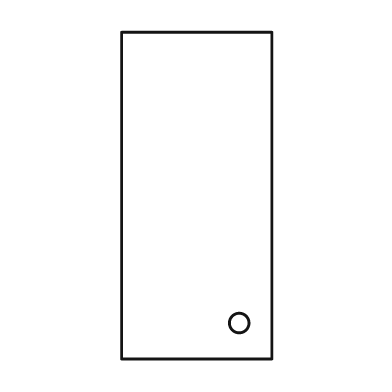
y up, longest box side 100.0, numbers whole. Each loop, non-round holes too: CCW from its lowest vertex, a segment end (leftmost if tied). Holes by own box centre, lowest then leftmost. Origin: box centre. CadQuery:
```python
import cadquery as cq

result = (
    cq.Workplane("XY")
    .moveTo(-23.0, -50.0)
    .lineTo(23.0, -50.0)
    .lineTo(23.0, 50.0)
    .lineTo(-23.0, 50.0)
    .close()
    .moveTo(13.0, -39.0)
    .circle(3.0)
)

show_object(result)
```